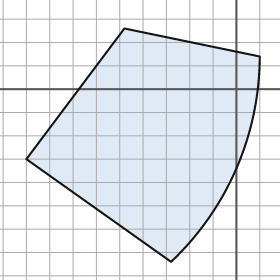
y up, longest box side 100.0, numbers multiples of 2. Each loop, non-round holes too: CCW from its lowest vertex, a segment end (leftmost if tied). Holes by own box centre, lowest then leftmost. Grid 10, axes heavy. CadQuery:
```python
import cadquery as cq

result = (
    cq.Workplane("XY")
    .moveTo(-28.0, -74.0)
    .threePointArc((0.0, -34.0), (10.0, 14.0))
    .lineTo(-48.0, 26.0)
    .lineTo(-90.0, -30.0)
    .close()
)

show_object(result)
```